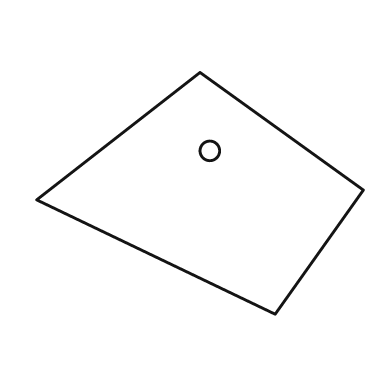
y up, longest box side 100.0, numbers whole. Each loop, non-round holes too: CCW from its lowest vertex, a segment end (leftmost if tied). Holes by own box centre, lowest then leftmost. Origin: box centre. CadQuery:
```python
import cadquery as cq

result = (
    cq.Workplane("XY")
    .moveTo(23.0, -37.0)
    .lineTo(50.0, 1.0)
    .lineTo(0.0, 37.0)
    .lineTo(-50.0, -2.0)
    .close()
    .moveTo(3.0, 13.0)
    .circle(3.0)
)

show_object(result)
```